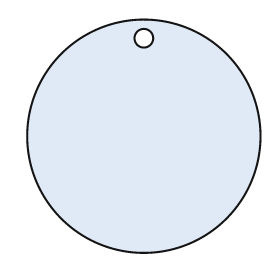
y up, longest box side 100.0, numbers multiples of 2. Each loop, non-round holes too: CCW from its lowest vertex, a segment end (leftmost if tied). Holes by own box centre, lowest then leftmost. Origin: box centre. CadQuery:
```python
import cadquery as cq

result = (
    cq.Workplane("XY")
    .moveTo(0.0, 0.0)
    .circle(50.0)
    .moveTo(0.0, 42.0)
    .circle(4.0)
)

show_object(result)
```